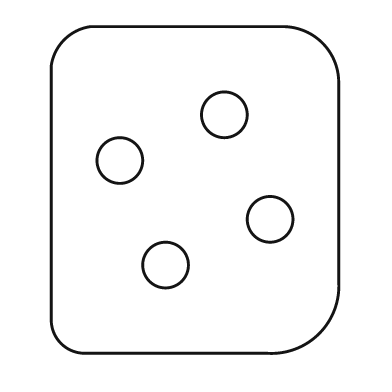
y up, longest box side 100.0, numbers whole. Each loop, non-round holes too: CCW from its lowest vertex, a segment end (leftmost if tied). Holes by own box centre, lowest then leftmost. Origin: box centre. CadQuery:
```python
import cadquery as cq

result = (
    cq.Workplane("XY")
    .moveTo(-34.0, -50.0)
    .lineTo(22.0, -50.0)
    .threePointArc((38.0, -44.0), (44.0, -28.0))
    .lineTo(44.0, 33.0)
    .threePointArc((39.0, 45.0), (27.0, 50.0))
    .lineTo(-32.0, 50.0)
    .threePointArc((-40.0, 46.0), (-44.0, 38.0))
    .lineTo(-44.0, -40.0)
    .threePointArc((-41.0, -47.0), (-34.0, -50.0))
    .close()
    .moveTo(-9.0, -23.0)
    .circle(7.0)
    .moveTo(23.0, -9.0)
    .circle(7.0)
    .moveTo(-23.0, 9.0)
    .circle(7.0)
    .moveTo(9.0, 23.0)
    .circle(7.0)
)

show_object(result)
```